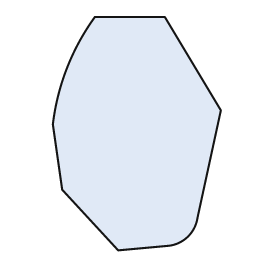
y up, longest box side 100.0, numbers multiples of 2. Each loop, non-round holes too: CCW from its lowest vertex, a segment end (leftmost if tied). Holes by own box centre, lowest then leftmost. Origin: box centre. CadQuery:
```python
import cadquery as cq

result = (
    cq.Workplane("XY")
    .moveTo(-8.0, -50.0)
    .lineTo(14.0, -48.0)
    .threePointArc((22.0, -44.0), (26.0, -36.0))
    .lineTo(36.0, 10.0)
    .lineTo(12.0, 50.0)
    .lineTo(-18.0, 50.0)
    .threePointArc((-30.0, 28.0), (-36.0, 4.0))
    .lineTo(-32.0, -24.0)
    .close()
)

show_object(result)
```